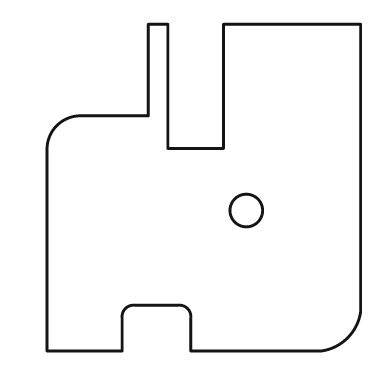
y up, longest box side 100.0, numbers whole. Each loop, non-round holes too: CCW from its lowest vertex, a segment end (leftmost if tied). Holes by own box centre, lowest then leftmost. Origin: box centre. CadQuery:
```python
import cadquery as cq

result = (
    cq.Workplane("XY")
    .moveTo(-48.0, -50.0)
    .lineTo(-25.0, -50.0)
    .lineTo(-25.0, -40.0)
    .threePointArc((-24.0, -37.0), (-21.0, -36.0))
    .lineTo(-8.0, -36.0)
    .threePointArc((-5.0, -37.0), (-4.0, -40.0))
    .lineTo(-4.0, -50.0)
    .lineTo(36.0, -50.0)
    .threePointArc((44.0, -46.0), (48.0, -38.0))
    .lineTo(48.0, 50.0)
    .lineTo(6.0, 50.0)
    .lineTo(6.0, 12.0)
    .lineTo(-11.0, 12.0)
    .lineTo(-11.0, 50.0)
    .lineTo(-17.0, 50.0)
    .lineTo(-17.0, 22.0)
    .lineTo(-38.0, 22.0)
    .threePointArc((-45.0, 19.0), (-48.0, 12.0))
    .close()
    .moveTo(13.0, -7.0)
    .circle(5.0)
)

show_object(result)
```